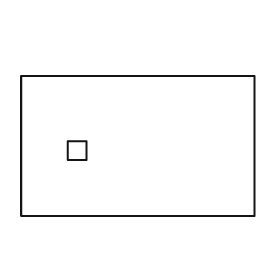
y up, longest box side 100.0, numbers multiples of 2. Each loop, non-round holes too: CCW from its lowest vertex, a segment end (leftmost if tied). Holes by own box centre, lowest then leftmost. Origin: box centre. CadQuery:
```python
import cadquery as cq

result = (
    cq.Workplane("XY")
    .moveTo(-50.0, -30.0)
    .lineTo(50.0, -30.0)
    .lineTo(50.0, 30.0)
    .lineTo(-50.0, 30.0)
    .close()
    .moveTo(-30.0, -6.0)
    .lineTo(-22.0, -6.0)
    .lineTo(-22.0, 2.0)
    .lineTo(-30.0, 2.0)
    .close()
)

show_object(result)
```